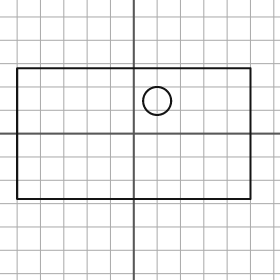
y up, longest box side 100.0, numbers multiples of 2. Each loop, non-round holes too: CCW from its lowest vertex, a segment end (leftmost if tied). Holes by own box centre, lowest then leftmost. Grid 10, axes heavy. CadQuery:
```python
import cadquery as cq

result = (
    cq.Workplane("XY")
    .moveTo(-50.0, -28.0)
    .lineTo(50.0, -28.0)
    .lineTo(50.0, 28.0)
    .lineTo(-50.0, 28.0)
    .close()
    .moveTo(10.0, 14.0)
    .circle(6.0)
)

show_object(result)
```